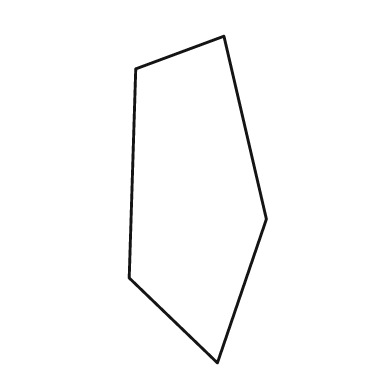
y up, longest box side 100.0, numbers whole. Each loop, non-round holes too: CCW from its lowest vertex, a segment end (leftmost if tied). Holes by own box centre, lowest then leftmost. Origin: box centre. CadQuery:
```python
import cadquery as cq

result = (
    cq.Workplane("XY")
    .moveTo(6.0, -50.0)
    .lineTo(21.0, -6.0)
    .lineTo(8.0, 50.0)
    .lineTo(-19.0, 40.0)
    .lineTo(-21.0, -24.0)
    .close()
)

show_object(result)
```